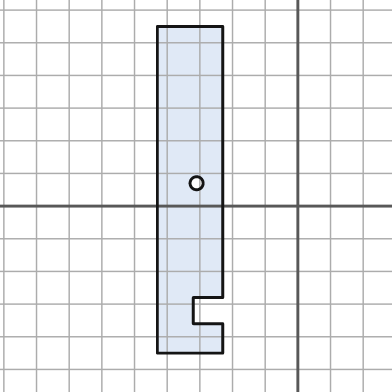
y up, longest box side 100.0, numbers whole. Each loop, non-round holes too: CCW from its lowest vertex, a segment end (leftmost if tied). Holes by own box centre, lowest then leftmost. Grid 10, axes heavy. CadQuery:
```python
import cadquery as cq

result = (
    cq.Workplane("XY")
    .moveTo(-43.0, -45.0)
    .lineTo(-23.0, -45.0)
    .lineTo(-23.0, -36.0)
    .lineTo(-32.0, -36.0)
    .lineTo(-32.0, -28.0)
    .lineTo(-23.0, -28.0)
    .lineTo(-23.0, 55.0)
    .lineTo(-43.0, 55.0)
    .close()
    .moveTo(-31.0, 7.0)
    .circle(2.0)
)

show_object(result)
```